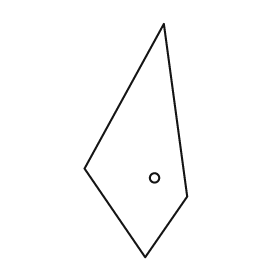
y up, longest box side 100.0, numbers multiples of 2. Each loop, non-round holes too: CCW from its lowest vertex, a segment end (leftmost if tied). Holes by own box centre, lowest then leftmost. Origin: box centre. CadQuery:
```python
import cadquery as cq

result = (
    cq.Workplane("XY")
    .moveTo(4.0, -50.0)
    .lineTo(22.0, -24.0)
    .lineTo(12.0, 50.0)
    .lineTo(-22.0, -12.0)
    .close()
    .moveTo(8.0, -16.0)
    .circle(2.0)
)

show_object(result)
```